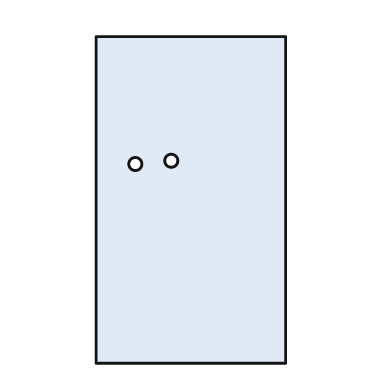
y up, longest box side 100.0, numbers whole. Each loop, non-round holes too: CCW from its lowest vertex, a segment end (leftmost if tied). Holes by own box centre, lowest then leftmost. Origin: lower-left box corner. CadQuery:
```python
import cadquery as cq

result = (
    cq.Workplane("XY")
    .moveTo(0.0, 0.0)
    .lineTo(58.0, 0.0)
    .lineTo(58.0, 100.0)
    .lineTo(0.0, 100.0)
    .close()
    .moveTo(12.0, 61.0)
    .circle(2.0)
    .moveTo(23.0, 62.0)
    .circle(2.0)
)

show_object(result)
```